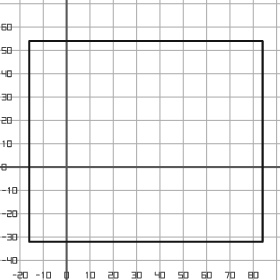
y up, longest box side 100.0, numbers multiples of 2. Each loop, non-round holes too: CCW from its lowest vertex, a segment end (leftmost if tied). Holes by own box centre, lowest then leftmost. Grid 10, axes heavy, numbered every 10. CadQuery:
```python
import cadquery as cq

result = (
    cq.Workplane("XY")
    .moveTo(-16.0, -32.0)
    .lineTo(84.0, -32.0)
    .lineTo(84.0, 54.0)
    .lineTo(-16.0, 54.0)
    .close()
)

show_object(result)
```